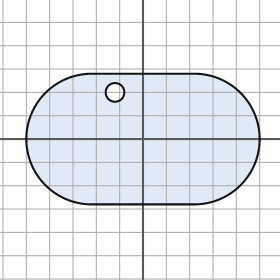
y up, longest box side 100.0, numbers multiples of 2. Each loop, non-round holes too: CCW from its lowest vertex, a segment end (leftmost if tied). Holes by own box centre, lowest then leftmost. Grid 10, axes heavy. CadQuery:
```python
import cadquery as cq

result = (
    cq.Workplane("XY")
    .moveTo(-22.0, -28.0)
    .lineTo(22.0, -28.0)
    .threePointArc((50.0, 0.0), (22.0, 28.0))
    .lineTo(-22.0, 28.0)
    .threePointArc((-50.0, 0.0), (-22.0, -28.0))
    .close()
    .moveTo(-12.0, 20.0)
    .circle(4.0)
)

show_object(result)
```